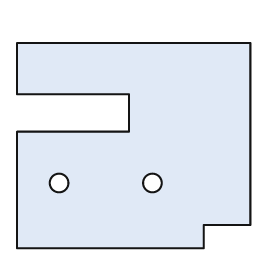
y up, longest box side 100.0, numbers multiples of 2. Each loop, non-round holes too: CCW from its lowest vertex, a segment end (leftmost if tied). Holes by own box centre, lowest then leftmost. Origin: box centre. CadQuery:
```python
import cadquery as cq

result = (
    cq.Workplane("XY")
    .moveTo(-50.0, -44.0)
    .lineTo(30.0, -44.0)
    .lineTo(30.0, -34.0)
    .lineTo(50.0, -34.0)
    .lineTo(50.0, 44.0)
    .lineTo(-50.0, 44.0)
    .lineTo(-50.0, 22.0)
    .lineTo(-2.0, 22.0)
    .lineTo(-2.0, 6.0)
    .lineTo(-50.0, 6.0)
    .close()
    .moveTo(-32.0, -16.0)
    .circle(4.0)
    .moveTo(8.0, -16.0)
    .circle(4.0)
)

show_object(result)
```